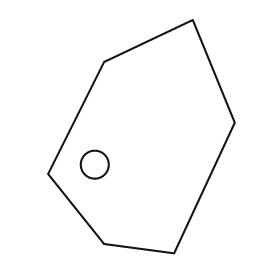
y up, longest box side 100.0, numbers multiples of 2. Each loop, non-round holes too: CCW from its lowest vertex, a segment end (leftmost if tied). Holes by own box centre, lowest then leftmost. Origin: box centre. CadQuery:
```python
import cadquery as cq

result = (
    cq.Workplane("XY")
    .moveTo(14.0, -50.0)
    .lineTo(40.0, 6.0)
    .lineTo(22.0, 50.0)
    .lineTo(-16.0, 32.0)
    .lineTo(-40.0, -16.0)
    .lineTo(-16.0, -46.0)
    .close()
    .moveTo(-20.0, -12.0)
    .circle(6.0)
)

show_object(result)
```